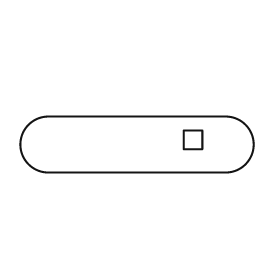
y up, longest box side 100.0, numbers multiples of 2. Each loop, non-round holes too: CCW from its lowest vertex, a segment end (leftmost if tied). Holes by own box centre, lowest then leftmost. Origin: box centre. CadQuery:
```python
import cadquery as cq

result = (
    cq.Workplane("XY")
    .moveTo(-38.0, -12.0)
    .lineTo(38.0, -12.0)
    .threePointArc((50.0, 0.0), (38.0, 12.0))
    .lineTo(-38.0, 12.0)
    .threePointArc((-50.0, 0.0), (-38.0, -12.0))
    .close()
    .moveTo(20.0, -2.0)
    .lineTo(28.0, -2.0)
    .lineTo(28.0, 6.0)
    .lineTo(20.0, 6.0)
    .close()
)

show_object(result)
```